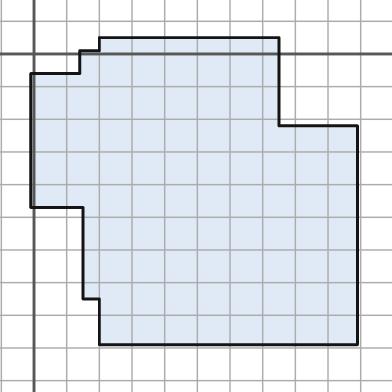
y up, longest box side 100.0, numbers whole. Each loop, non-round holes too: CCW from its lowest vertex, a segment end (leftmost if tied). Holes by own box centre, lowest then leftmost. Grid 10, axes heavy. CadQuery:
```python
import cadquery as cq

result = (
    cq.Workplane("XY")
    .moveTo(20.0, -89.0)
    .lineTo(99.0, -89.0)
    .lineTo(99.0, -22.0)
    .lineTo(75.0, -22.0)
    .lineTo(75.0, 5.0)
    .lineTo(20.0, 5.0)
    .lineTo(20.0, 1.0)
    .lineTo(14.0, 1.0)
    .lineTo(14.0, -6.0)
    .lineTo(-1.0, -6.0)
    .lineTo(-1.0, -47.0)
    .lineTo(15.0, -47.0)
    .lineTo(15.0, -75.0)
    .lineTo(20.0, -75.0)
    .close()
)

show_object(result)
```